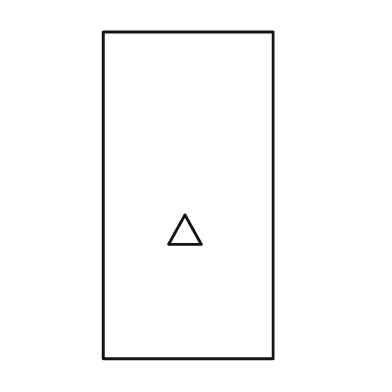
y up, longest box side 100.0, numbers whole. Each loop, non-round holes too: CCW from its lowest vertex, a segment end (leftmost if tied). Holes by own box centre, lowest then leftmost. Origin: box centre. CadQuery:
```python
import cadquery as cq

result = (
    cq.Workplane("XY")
    .moveTo(-26.0, -50.0)
    .lineTo(26.0, -50.0)
    .lineTo(26.0, 50.0)
    .lineTo(-26.0, 50.0)
    .close()
    .moveTo(-6.0, -15.0)
    .lineTo(4.0, -15.0)
    .lineTo(-1.0, -6.0)
    .close()
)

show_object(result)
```